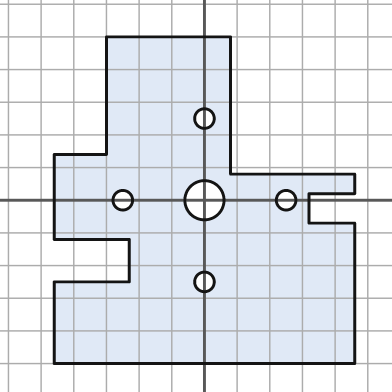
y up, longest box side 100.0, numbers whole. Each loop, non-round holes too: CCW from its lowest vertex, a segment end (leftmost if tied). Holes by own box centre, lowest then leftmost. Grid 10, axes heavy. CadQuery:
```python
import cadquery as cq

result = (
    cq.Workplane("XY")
    .moveTo(-46.0, -50.0)
    .lineTo(46.0, -50.0)
    .lineTo(46.0, -7.0)
    .lineTo(32.0, -7.0)
    .lineTo(32.0, 2.0)
    .lineTo(46.0, 2.0)
    .lineTo(46.0, 8.0)
    .lineTo(8.0, 8.0)
    .lineTo(8.0, 50.0)
    .lineTo(-30.0, 50.0)
    .lineTo(-30.0, 14.0)
    .lineTo(-46.0, 14.0)
    .lineTo(-46.0, -12.0)
    .lineTo(-23.0, -12.0)
    .lineTo(-23.0, -25.0)
    .lineTo(-46.0, -25.0)
    .close()
    .moveTo(0.0, -25.0)
    .circle(3.0)
    .moveTo(-25.0, 0.0)
    .circle(3.0)
    .moveTo(0.0, 0.0)
    .circle(6.0)
    .moveTo(25.0, 0.0)
    .circle(3.0)
    .moveTo(0.0, 25.0)
    .circle(3.0)
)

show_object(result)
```